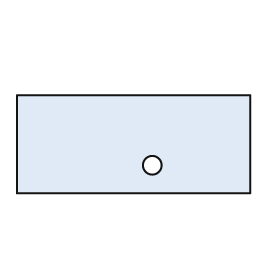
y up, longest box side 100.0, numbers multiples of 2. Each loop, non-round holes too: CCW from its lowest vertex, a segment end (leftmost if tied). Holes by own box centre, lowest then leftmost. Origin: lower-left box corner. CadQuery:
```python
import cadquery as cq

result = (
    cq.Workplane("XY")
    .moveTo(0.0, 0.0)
    .lineTo(100.0, 0.0)
    .lineTo(100.0, 42.0)
    .lineTo(0.0, 42.0)
    .close()
    .moveTo(58.0, 12.0)
    .circle(4.0)
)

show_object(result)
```